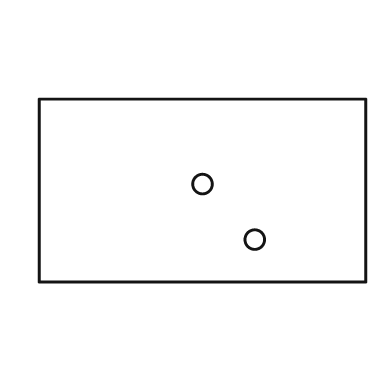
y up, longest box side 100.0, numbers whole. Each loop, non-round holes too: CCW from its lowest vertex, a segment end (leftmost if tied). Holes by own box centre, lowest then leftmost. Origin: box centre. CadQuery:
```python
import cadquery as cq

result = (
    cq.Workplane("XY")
    .moveTo(-50.0, -28.0)
    .lineTo(50.0, -28.0)
    .lineTo(50.0, 28.0)
    .lineTo(-50.0, 28.0)
    .close()
    .moveTo(16.0, -15.0)
    .circle(3.0)
    .moveTo(0.0, 2.0)
    .circle(3.0)
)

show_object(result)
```